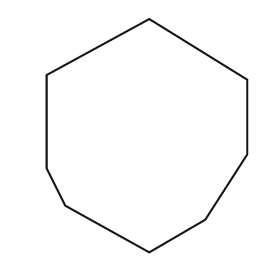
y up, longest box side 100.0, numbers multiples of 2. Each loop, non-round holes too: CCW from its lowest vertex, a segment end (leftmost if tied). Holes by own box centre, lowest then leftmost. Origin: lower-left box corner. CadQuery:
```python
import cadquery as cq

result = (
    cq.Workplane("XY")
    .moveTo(44.0, 0.0)
    .lineTo(68.0, 14.0)
    .lineTo(86.0, 42.0)
    .lineTo(86.0, 74.0)
    .lineTo(44.0, 100.0)
    .lineTo(0.0, 76.0)
    .lineTo(0.0, 36.0)
    .lineTo(8.0, 20.0)
    .close()
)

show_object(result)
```